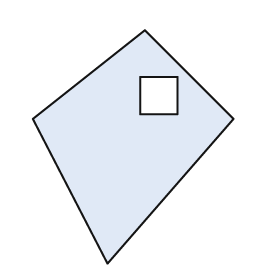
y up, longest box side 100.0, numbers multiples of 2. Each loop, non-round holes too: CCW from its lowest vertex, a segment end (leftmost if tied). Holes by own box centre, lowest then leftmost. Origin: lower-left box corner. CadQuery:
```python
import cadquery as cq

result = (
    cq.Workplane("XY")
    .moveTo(32.0, 0.0)
    .lineTo(86.0, 62.0)
    .lineTo(48.0, 100.0)
    .lineTo(0.0, 62.0)
    .close()
    .moveTo(46.0, 64.0)
    .lineTo(62.0, 64.0)
    .lineTo(62.0, 80.0)
    .lineTo(46.0, 80.0)
    .close()
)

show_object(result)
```